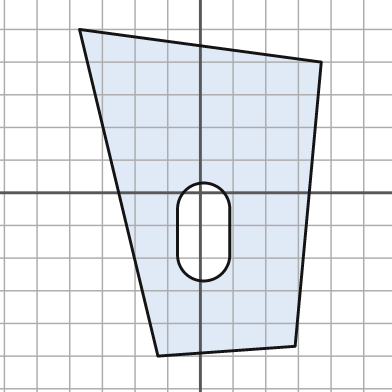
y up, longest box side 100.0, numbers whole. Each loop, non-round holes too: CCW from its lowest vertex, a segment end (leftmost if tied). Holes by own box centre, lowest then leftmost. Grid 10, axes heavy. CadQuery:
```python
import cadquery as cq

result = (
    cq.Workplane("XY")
    .moveTo(-13.0, -50.0)
    .lineTo(29.0, -47.0)
    .lineTo(37.0, 40.0)
    .lineTo(-37.0, 50.0)
    .close()
    .moveTo(-7.0, -19.0)
    .threePointArc((1.0, -27.0), (9.0, -19.0))
    .lineTo(9.0, -5.0)
    .threePointArc((1.0, 3.0), (-7.0, -5.0))
    .close()
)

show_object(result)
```